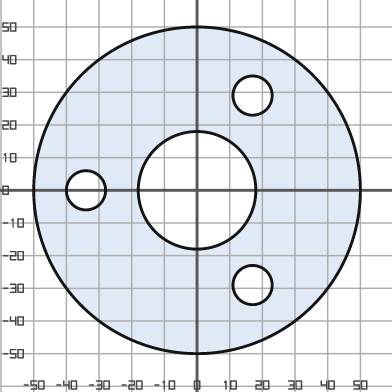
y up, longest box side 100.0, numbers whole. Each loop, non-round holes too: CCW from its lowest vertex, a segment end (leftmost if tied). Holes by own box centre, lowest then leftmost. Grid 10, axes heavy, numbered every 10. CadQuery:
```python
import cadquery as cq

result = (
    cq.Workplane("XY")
    .moveTo(0.0, 0.0)
    .circle(50.0)
    .moveTo(17.0, -29.0)
    .circle(6.0)
    .moveTo(-34.0, 0.0)
    .circle(6.0)
    .moveTo(0.0, 0.0)
    .circle(18.0)
    .moveTo(17.0, 29.0)
    .circle(6.0)
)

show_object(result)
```